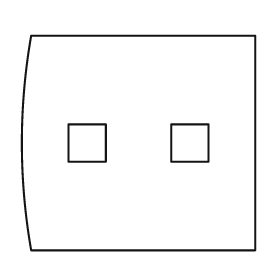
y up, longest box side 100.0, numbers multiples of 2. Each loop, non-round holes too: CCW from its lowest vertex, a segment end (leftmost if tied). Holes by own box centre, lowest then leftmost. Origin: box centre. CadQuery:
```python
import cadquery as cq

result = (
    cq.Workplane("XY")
    .moveTo(-46.0, -46.0)
    .lineTo(50.0, -46.0)
    .lineTo(50.0, 46.0)
    .lineTo(-46.0, 46.0)
    .threePointArc((-50.0, 0.0), (-46.0, -46.0))
    .close()
    .moveTo(-30.0, -8.0)
    .lineTo(-14.0, -8.0)
    .lineTo(-14.0, 8.0)
    .lineTo(-30.0, 8.0)
    .close()
    .moveTo(14.0, -8.0)
    .lineTo(30.0, -8.0)
    .lineTo(30.0, 8.0)
    .lineTo(14.0, 8.0)
    .close()
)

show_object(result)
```